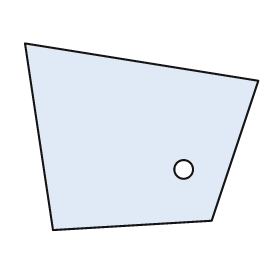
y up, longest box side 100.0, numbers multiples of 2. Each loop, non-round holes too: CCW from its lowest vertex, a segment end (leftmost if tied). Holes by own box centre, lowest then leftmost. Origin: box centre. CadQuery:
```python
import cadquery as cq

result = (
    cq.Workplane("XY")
    .moveTo(-38.0, -40.0)
    .lineTo(30.0, -36.0)
    .lineTo(50.0, 24.0)
    .lineTo(-50.0, 40.0)
    .close()
    .moveTo(18.0, -14.0)
    .circle(4.0)
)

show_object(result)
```